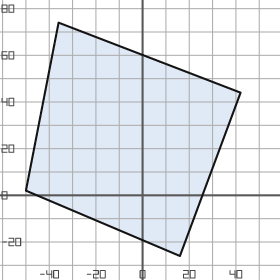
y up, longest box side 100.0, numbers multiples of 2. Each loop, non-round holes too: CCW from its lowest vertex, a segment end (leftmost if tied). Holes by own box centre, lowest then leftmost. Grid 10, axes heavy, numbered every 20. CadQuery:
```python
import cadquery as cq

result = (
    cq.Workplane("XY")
    .moveTo(16.0, -26.0)
    .lineTo(42.0, 44.0)
    .lineTo(-36.0, 74.0)
    .lineTo(-50.0, 2.0)
    .close()
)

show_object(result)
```